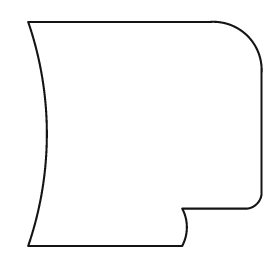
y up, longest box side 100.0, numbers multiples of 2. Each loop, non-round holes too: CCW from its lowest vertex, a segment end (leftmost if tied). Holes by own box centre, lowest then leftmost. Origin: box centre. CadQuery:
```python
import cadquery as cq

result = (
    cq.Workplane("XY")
    .moveTo(-50.0, -48.0)
    .lineTo(16.0, -48.0)
    .threePointArc((18.0, -40.0), (16.0, -32.0))
    .lineTo(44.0, -32.0)
    .threePointArc((48.0, -30.0), (50.0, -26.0))
    .lineTo(50.0, 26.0)
    .threePointArc((44.0, 42.0), (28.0, 48.0))
    .lineTo(-50.0, 48.0)
    .threePointArc((-42.0, 0.0), (-50.0, -48.0))
    .close()
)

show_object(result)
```